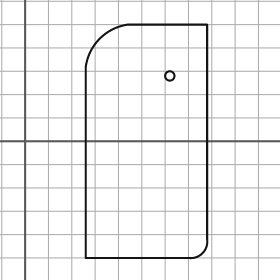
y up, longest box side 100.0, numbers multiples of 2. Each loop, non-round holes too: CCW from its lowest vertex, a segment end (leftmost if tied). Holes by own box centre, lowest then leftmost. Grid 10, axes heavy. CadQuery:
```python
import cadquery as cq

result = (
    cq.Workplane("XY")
    .moveTo(26.0, -50.0)
    .lineTo(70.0, -50.0)
    .threePointArc((76.0, -48.0), (78.0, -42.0))
    .lineTo(78.0, 50.0)
    .lineTo(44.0, 50.0)
    .threePointArc((32.0, 44.0), (26.0, 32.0))
    .close()
    .moveTo(62.0, 28.0)
    .circle(2.0)
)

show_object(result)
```